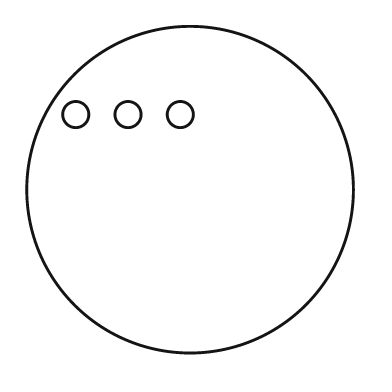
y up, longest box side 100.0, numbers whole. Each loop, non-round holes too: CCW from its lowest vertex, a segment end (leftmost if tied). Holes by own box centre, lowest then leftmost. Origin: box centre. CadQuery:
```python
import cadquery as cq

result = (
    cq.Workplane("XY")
    .moveTo(0.0, 0.0)
    .circle(50.0)
    .moveTo(-35.0, 23.0)
    .circle(4.0)
    .moveTo(-19.0, 23.0)
    .circle(4.0)
    .moveTo(-3.0, 23.0)
    .circle(4.0)
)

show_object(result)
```